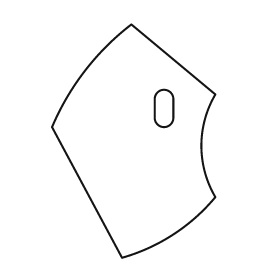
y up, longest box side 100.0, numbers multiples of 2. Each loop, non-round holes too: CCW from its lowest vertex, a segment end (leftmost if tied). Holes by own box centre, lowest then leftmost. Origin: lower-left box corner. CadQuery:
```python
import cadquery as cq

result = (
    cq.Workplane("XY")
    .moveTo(30.0, 0.0)
    .threePointArc((52.0, 10.0), (70.0, 26.0))
    .threePointArc((64.0, 48.0), (70.0, 70.0))
    .lineTo(34.0, 100.0)
    .threePointArc((14.0, 80.0), (0.0, 56.0))
    .close()
    .moveTo(44.0, 60.0)
    .threePointArc((48.0, 56.0), (52.0, 60.0))
    .lineTo(52.0, 68.0)
    .threePointArc((48.0, 72.0), (44.0, 68.0))
    .close()
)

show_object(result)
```